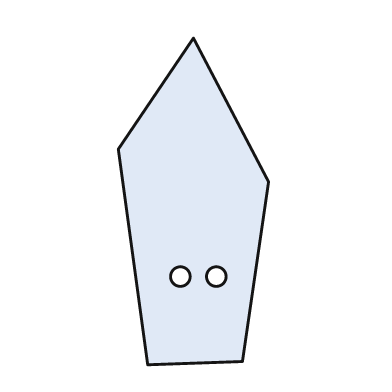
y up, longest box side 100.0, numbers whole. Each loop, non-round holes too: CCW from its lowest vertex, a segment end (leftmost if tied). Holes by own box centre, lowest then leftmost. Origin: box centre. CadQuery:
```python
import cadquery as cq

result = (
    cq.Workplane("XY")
    .moveTo(-14.0, -50.0)
    .lineTo(15.0, -49.0)
    .lineTo(23.0, 6.0)
    .lineTo(0.0, 50.0)
    .lineTo(-23.0, 16.0)
    .close()
    .moveTo(-4.0, -23.0)
    .circle(3.0)
    .moveTo(7.0, -23.0)
    .circle(3.0)
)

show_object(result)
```